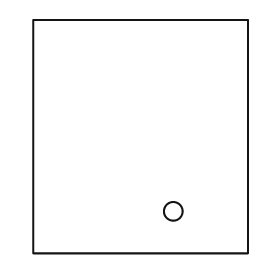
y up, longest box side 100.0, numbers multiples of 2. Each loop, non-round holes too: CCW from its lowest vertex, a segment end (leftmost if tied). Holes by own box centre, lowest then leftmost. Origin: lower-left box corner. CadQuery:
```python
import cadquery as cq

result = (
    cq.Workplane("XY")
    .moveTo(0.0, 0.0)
    .lineTo(92.0, 0.0)
    .lineTo(92.0, 100.0)
    .lineTo(0.0, 100.0)
    .close()
    .moveTo(60.0, 18.0)
    .circle(4.0)
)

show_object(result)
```